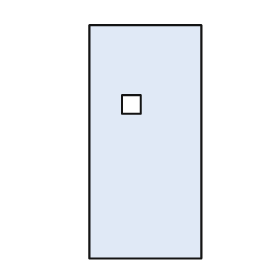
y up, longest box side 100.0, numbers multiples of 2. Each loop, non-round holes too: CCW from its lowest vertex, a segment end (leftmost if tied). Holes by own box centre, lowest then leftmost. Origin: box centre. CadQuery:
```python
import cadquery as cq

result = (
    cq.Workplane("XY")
    .moveTo(-24.0, -50.0)
    .lineTo(24.0, -50.0)
    .lineTo(24.0, 50.0)
    .lineTo(-24.0, 50.0)
    .close()
    .moveTo(-10.0, 12.0)
    .lineTo(-2.0, 12.0)
    .lineTo(-2.0, 20.0)
    .lineTo(-10.0, 20.0)
    .close()
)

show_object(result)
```